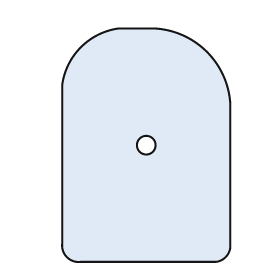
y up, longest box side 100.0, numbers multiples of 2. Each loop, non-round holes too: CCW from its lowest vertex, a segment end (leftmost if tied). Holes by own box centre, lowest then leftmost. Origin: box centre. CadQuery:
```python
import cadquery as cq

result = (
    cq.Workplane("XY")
    .moveTo(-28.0, -50.0)
    .lineTo(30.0, -50.0)
    .threePointArc((34.0, -48.0), (36.0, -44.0))
    .lineTo(36.0, 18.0)
    .threePointArc((26.0, 40.0), (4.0, 50.0))
    .lineTo(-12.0, 50.0)
    .threePointArc((-28.0, 42.0), (-36.0, 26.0))
    .lineTo(-36.0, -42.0)
    .threePointArc((-34.0, -48.0), (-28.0, -50.0))
    .close()
    .moveTo(0.0, 0.0)
    .circle(4.0)
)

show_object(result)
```